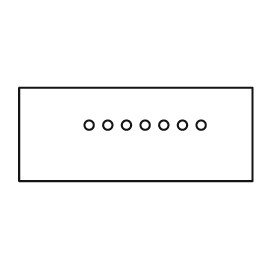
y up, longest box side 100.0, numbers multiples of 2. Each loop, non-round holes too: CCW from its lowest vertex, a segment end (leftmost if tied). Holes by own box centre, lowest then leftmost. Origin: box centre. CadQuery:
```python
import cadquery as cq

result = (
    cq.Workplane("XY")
    .moveTo(-50.0, -20.0)
    .lineTo(50.0, -20.0)
    .lineTo(50.0, 20.0)
    .lineTo(-50.0, 20.0)
    .close()
    .moveTo(-20.0, 4.0)
    .circle(2.0)
    .moveTo(-12.0, 4.0)
    .circle(2.0)
    .moveTo(-4.0, 4.0)
    .circle(2.0)
    .moveTo(4.0, 4.0)
    .circle(2.0)
    .moveTo(12.0, 4.0)
    .circle(2.0)
    .moveTo(20.0, 4.0)
    .circle(2.0)
    .moveTo(28.0, 4.0)
    .circle(2.0)
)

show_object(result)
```